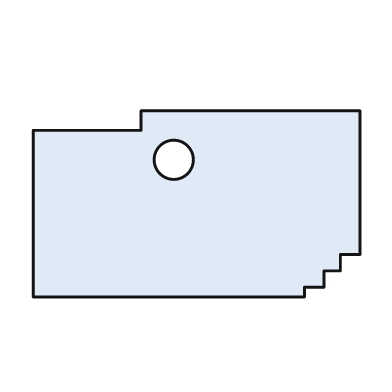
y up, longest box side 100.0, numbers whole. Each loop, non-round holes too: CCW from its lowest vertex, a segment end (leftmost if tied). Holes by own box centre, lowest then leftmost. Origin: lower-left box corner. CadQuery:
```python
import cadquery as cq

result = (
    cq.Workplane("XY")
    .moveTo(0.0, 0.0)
    .lineTo(83.0, 0.0)
    .lineTo(83.0, 3.0)
    .lineTo(89.0, 3.0)
    .lineTo(89.0, 8.0)
    .lineTo(94.0, 8.0)
    .lineTo(94.0, 13.0)
    .lineTo(100.0, 13.0)
    .lineTo(100.0, 57.0)
    .lineTo(33.0, 57.0)
    .lineTo(33.0, 51.0)
    .lineTo(0.0, 51.0)
    .close()
    .moveTo(43.0, 42.0)
    .circle(6.0)
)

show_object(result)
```